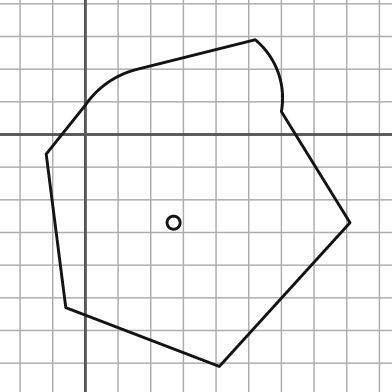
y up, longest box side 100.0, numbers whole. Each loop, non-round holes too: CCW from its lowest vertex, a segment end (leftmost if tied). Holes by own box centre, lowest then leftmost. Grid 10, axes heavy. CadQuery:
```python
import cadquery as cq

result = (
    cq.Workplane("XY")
    .moveTo(41.0, -71.0)
    .lineTo(81.0, -27.0)
    .lineTo(60.0, 7.0)
    .threePointArc((59.0, 19.0), (52.0, 29.0))
    .lineTo(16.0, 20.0)
    .threePointArc((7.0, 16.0), (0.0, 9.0))
    .lineTo(-12.0, -6.0)
    .lineTo(-6.0, -53.0)
    .close()
    .moveTo(27.0, -27.0)
    .circle(2.0)
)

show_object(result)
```